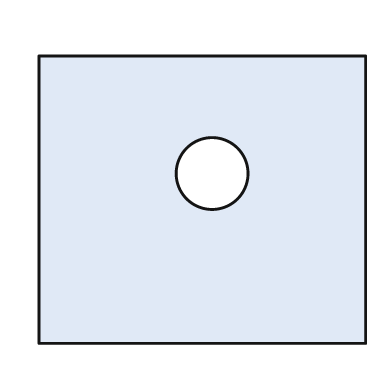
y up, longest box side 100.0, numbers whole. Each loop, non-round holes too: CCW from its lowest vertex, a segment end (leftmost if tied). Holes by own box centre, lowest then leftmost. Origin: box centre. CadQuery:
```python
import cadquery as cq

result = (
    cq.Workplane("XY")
    .moveTo(-50.0, -44.0)
    .lineTo(50.0, -44.0)
    .lineTo(50.0, 44.0)
    .lineTo(-50.0, 44.0)
    .close()
    .moveTo(3.0, 8.0)
    .circle(11.0)
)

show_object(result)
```